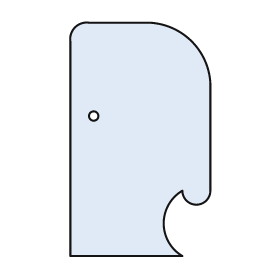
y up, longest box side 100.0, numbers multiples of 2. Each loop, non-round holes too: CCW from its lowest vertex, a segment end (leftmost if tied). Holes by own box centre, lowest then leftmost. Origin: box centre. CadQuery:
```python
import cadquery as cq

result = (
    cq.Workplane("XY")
    .moveTo(-30.0, -50.0)
    .lineTo(18.0, -50.0)
    .threePointArc((10.0, -36.0), (18.0, -22.0))
    .threePointArc((24.0, -28.0), (30.0, -22.0))
    .lineTo(30.0, 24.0)
    .threePointArc((22.0, 42.0), (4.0, 50.0))
    .lineTo(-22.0, 50.0)
    .threePointArc((-28.0, 48.0), (-30.0, 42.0))
    .close()
    .moveTo(-20.0, 10.0)
    .circle(2.0)
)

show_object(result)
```